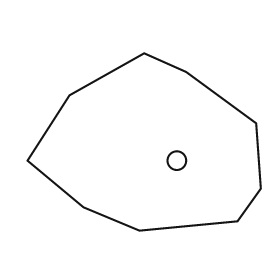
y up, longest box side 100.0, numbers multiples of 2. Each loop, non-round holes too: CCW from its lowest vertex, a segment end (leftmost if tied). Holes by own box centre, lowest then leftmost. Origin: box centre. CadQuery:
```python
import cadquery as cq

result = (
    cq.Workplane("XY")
    .moveTo(-2.0, -38.0)
    .lineTo(40.0, -34.0)
    .lineTo(50.0, -20.0)
    .lineTo(48.0, 8.0)
    .lineTo(18.0, 30.0)
    .lineTo(0.0, 38.0)
    .lineTo(-32.0, 20.0)
    .lineTo(-50.0, -8.0)
    .lineTo(-26.0, -28.0)
    .close()
    .moveTo(14.0, -8.0)
    .circle(4.0)
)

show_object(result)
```